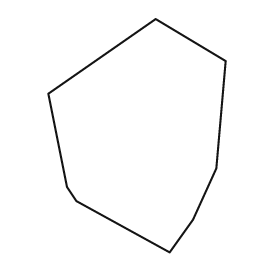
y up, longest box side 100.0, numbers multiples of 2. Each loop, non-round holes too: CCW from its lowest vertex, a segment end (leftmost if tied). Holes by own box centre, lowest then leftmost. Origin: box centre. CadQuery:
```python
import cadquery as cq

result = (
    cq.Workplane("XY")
    .moveTo(14.0, -50.0)
    .lineTo(24.0, -36.0)
    .lineTo(34.0, -14.0)
    .lineTo(38.0, 32.0)
    .lineTo(8.0, 50.0)
    .lineTo(-38.0, 18.0)
    .lineTo(-30.0, -22.0)
    .lineTo(-26.0, -28.0)
    .close()
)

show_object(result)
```